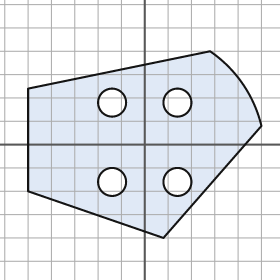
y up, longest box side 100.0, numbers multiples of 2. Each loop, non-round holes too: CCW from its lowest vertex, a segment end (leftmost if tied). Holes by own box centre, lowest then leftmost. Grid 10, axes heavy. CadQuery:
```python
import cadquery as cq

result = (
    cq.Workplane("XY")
    .moveTo(8.0, -40.0)
    .lineTo(50.0, 8.0)
    .threePointArc((42.0, 26.0), (28.0, 40.0))
    .lineTo(-50.0, 24.0)
    .lineTo(-50.0, -20.0)
    .close()
    .moveTo(-14.0, -16.0)
    .circle(6.0)
    .moveTo(14.0, -16.0)
    .circle(6.0)
    .moveTo(-14.0, 18.0)
    .circle(6.0)
    .moveTo(14.0, 18.0)
    .circle(6.0)
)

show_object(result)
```